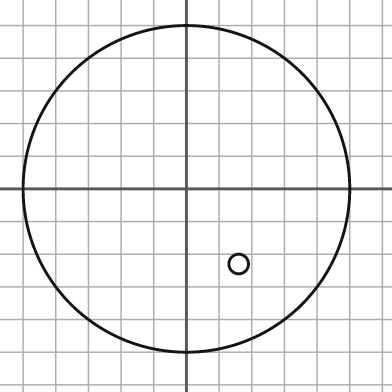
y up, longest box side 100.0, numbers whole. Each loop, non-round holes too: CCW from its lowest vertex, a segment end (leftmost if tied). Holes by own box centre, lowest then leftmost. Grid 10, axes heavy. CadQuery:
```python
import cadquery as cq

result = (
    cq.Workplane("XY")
    .moveTo(0.0, 0.0)
    .circle(50.0)
    .moveTo(16.0, -23.0)
    .circle(3.0)
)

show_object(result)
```